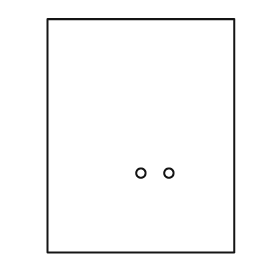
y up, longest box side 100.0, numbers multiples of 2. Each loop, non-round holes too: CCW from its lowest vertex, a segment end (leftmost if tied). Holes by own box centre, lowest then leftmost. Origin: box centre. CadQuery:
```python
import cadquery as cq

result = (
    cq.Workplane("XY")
    .moveTo(-40.0, -50.0)
    .lineTo(40.0, -50.0)
    .lineTo(40.0, 50.0)
    .lineTo(-40.0, 50.0)
    .close()
    .moveTo(0.0, -16.0)
    .circle(2.0)
    .moveTo(12.0, -16.0)
    .circle(2.0)
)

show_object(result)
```